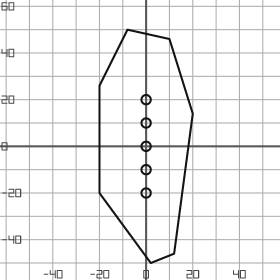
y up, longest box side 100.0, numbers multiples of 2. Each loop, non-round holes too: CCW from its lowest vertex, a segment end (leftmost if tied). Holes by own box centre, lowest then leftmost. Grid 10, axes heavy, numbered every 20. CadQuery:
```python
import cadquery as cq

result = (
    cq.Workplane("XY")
    .moveTo(2.0, -50.0)
    .lineTo(12.0, -46.0)
    .lineTo(20.0, 14.0)
    .lineTo(10.0, 46.0)
    .lineTo(-8.0, 50.0)
    .lineTo(-20.0, 26.0)
    .lineTo(-20.0, -20.0)
    .close()
    .moveTo(0.0, -20.0)
    .circle(2.0)
    .moveTo(0.0, -10.0)
    .circle(2.0)
    .moveTo(0.0, 0.0)
    .circle(2.0)
    .moveTo(0.0, 10.0)
    .circle(2.0)
    .moveTo(0.0, 20.0)
    .circle(2.0)
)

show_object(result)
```